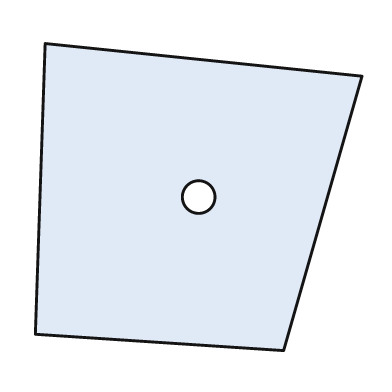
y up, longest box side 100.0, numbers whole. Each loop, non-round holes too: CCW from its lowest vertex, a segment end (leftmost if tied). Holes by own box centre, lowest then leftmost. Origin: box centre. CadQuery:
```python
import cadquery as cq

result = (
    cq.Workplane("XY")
    .moveTo(26.0, -47.0)
    .lineTo(50.0, 37.0)
    .lineTo(-47.0, 47.0)
    .lineTo(-50.0, -42.0)
    .close()
    .moveTo(0.0, 0.0)
    .circle(5.0)
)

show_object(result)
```